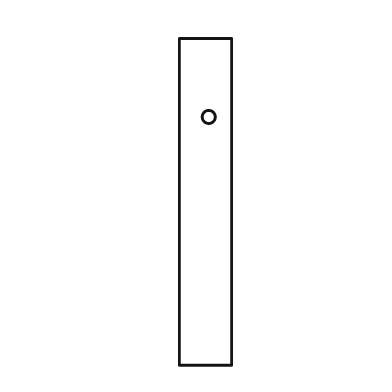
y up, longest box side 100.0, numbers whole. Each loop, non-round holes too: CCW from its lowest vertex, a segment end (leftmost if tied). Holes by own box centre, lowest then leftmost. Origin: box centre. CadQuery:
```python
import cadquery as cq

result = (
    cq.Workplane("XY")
    .moveTo(-8.0, -50.0)
    .lineTo(8.0, -50.0)
    .lineTo(8.0, 50.0)
    .lineTo(-8.0, 50.0)
    .close()
    .moveTo(1.0, 26.0)
    .circle(2.0)
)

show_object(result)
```